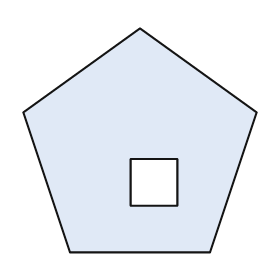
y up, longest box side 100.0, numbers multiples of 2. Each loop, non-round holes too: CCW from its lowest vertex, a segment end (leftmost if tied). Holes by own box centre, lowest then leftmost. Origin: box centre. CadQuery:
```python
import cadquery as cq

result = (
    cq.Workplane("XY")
    .moveTo(-30.0, -48.0)
    .lineTo(30.0, -48.0)
    .lineTo(50.0, 12.0)
    .lineTo(0.0, 48.0)
    .lineTo(-50.0, 12.0)
    .close()
    .moveTo(-4.0, -28.0)
    .lineTo(16.0, -28.0)
    .lineTo(16.0, -8.0)
    .lineTo(-4.0, -8.0)
    .close()
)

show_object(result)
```